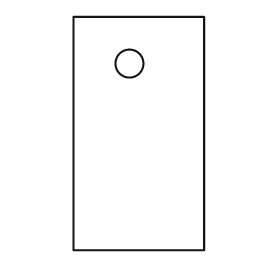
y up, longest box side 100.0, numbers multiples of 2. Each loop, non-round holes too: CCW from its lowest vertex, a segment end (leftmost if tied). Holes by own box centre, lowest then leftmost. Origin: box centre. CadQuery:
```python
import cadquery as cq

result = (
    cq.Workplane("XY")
    .moveTo(-28.0, -50.0)
    .lineTo(28.0, -50.0)
    .lineTo(28.0, 50.0)
    .lineTo(-28.0, 50.0)
    .close()
    .moveTo(-4.0, 30.0)
    .circle(6.0)
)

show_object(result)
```